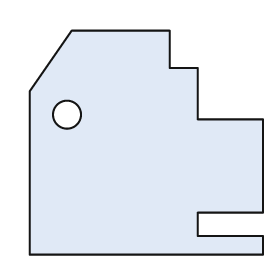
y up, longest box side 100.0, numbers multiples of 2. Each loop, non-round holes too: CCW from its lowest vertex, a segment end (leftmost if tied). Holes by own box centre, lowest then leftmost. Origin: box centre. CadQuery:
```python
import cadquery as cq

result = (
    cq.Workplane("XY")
    .moveTo(-50.0, -48.0)
    .lineTo(50.0, -48.0)
    .lineTo(50.0, -40.0)
    .lineTo(22.0, -40.0)
    .lineTo(22.0, -30.0)
    .lineTo(50.0, -30.0)
    .lineTo(50.0, 10.0)
    .lineTo(22.0, 10.0)
    .lineTo(22.0, 32.0)
    .lineTo(10.0, 32.0)
    .lineTo(10.0, 48.0)
    .lineTo(-32.0, 48.0)
    .lineTo(-50.0, 22.0)
    .close()
    .moveTo(-34.0, 12.0)
    .circle(6.0)
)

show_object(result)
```